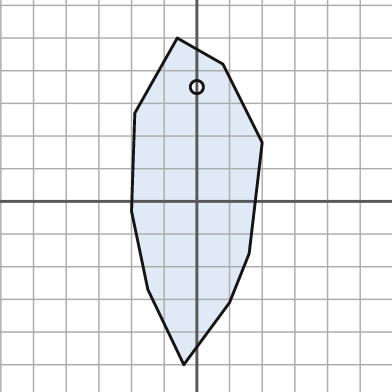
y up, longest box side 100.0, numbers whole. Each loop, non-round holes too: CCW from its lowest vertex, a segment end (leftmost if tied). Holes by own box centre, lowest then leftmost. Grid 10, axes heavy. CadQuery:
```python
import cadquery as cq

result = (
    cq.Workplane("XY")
    .moveTo(-4.0, -50.0)
    .lineTo(10.0, -31.0)
    .lineTo(16.0, -16.0)
    .lineTo(20.0, 18.0)
    .lineTo(8.0, 42.0)
    .lineTo(-6.0, 50.0)
    .lineTo(-19.0, 27.0)
    .lineTo(-20.0, -3.0)
    .lineTo(-15.0, -27.0)
    .close()
    .moveTo(0.0, 35.0)
    .circle(2.0)
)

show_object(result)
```